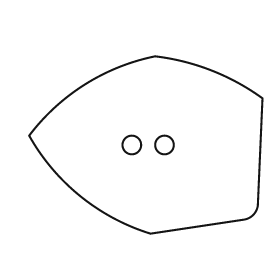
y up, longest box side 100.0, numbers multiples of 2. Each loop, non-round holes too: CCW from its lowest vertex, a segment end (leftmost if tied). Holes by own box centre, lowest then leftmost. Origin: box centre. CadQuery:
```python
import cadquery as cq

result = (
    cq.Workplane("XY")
    .moveTo(2.0, -38.0)
    .lineTo(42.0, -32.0)
    .threePointArc((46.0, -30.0), (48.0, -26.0))
    .lineTo(50.0, 20.0)
    .threePointArc((28.0, 32.0), (4.0, 38.0))
    .threePointArc((-26.0, 26.0), (-50.0, 4.0))
    .threePointArc((-28.0, -22.0), (2.0, -38.0))
    .close()
    .moveTo(-6.0, 0.0)
    .circle(4.0)
    .moveTo(8.0, 0.0)
    .circle(4.0)
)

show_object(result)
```